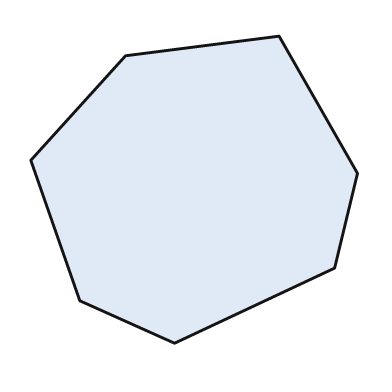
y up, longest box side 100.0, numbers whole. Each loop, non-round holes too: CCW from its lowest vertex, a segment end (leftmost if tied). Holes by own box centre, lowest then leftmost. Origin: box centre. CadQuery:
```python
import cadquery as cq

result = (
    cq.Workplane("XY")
    .moveTo(-6.0, -47.0)
    .lineTo(43.0, -24.0)
    .lineTo(50.0, 5.0)
    .lineTo(26.0, 47.0)
    .lineTo(-21.0, 41.0)
    .lineTo(-50.0, 9.0)
    .lineTo(-35.0, -34.0)
    .close()
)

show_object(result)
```